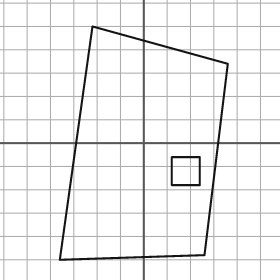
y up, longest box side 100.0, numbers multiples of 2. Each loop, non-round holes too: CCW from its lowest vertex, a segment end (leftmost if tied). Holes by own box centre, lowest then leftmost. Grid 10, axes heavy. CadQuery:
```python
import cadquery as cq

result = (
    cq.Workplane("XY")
    .moveTo(-36.0, -50.0)
    .lineTo(26.0, -48.0)
    .lineTo(36.0, 34.0)
    .lineTo(-22.0, 50.0)
    .close()
    .moveTo(12.0, -18.0)
    .lineTo(24.0, -18.0)
    .lineTo(24.0, -6.0)
    .lineTo(12.0, -6.0)
    .close()
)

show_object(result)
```